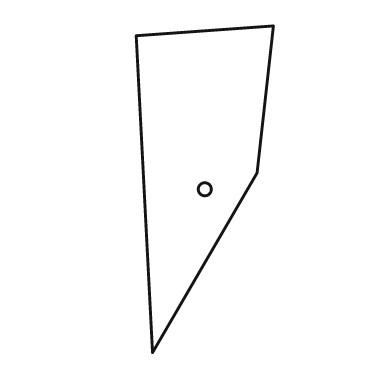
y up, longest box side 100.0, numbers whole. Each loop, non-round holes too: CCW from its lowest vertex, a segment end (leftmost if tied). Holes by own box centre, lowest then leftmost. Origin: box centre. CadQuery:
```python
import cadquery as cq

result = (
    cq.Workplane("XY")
    .moveTo(-16.0, -50.0)
    .lineTo(16.0, 5.0)
    .lineTo(21.0, 50.0)
    .lineTo(-21.0, 47.0)
    .close()
    .moveTo(0.0, 0.0)
    .circle(2.0)
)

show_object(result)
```